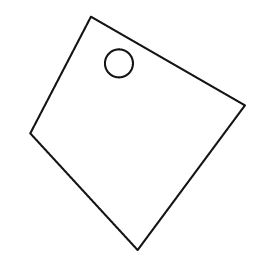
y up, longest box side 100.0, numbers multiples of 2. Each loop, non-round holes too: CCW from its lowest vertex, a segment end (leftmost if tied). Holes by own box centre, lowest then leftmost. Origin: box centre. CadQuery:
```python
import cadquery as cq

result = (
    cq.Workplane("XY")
    .moveTo(0.0, -50.0)
    .lineTo(46.0, 12.0)
    .lineTo(-20.0, 50.0)
    .lineTo(-46.0, 0.0)
    .close()
    .moveTo(-8.0, 30.0)
    .circle(6.0)
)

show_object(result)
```